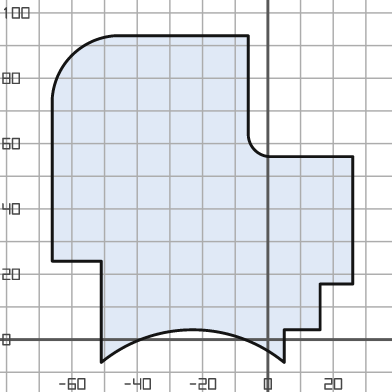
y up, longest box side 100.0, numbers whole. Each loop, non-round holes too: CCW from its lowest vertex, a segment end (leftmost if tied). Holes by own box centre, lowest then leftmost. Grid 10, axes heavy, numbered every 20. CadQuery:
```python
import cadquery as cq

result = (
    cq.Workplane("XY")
    .moveTo(-51.0, -7.0)
    .threePointArc((-23.0, 3.0), (5.0, -7.0))
    .lineTo(5.0, 3.0)
    .lineTo(16.0, 3.0)
    .lineTo(16.0, 17.0)
    .lineTo(26.0, 17.0)
    .lineTo(26.0, 56.0)
    .lineTo(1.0, 56.0)
    .threePointArc((-4.0, 58.0), (-6.0, 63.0))
    .lineTo(-6.0, 93.0)
    .lineTo(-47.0, 93.0)
    .threePointArc((-60.0, 87.0), (-66.0, 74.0))
    .lineTo(-66.0, 24.0)
    .lineTo(-51.0, 24.0)
    .close()
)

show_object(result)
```